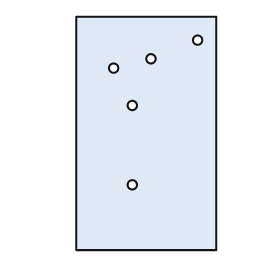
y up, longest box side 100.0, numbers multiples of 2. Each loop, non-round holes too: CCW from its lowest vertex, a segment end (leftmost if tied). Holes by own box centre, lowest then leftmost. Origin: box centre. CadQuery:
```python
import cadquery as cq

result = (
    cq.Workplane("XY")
    .moveTo(-30.0, -50.0)
    .lineTo(30.0, -50.0)
    .lineTo(30.0, 50.0)
    .lineTo(-30.0, 50.0)
    .close()
    .moveTo(-6.0, -22.0)
    .circle(2.0)
    .moveTo(-6.0, 12.0)
    .circle(2.0)
    .moveTo(-14.0, 28.0)
    .circle(2.0)
    .moveTo(2.0, 32.0)
    .circle(2.0)
    .moveTo(22.0, 40.0)
    .circle(2.0)
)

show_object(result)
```